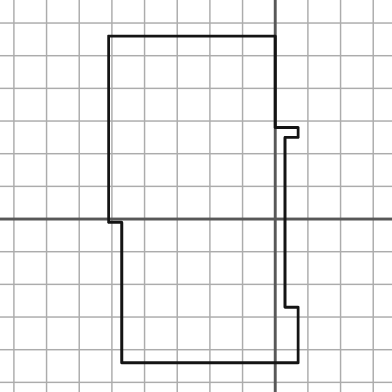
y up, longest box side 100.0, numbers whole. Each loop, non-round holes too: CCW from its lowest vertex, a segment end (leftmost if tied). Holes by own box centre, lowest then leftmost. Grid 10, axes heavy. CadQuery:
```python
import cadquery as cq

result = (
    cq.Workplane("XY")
    .moveTo(-47.0, -44.0)
    .lineTo(7.0, -44.0)
    .lineTo(7.0, -27.0)
    .lineTo(3.0, -27.0)
    .lineTo(3.0, 25.0)
    .lineTo(7.0, 25.0)
    .lineTo(7.0, 28.0)
    .lineTo(0.0, 28.0)
    .lineTo(0.0, 56.0)
    .lineTo(-51.0, 56.0)
    .lineTo(-51.0, -1.0)
    .lineTo(-47.0, -1.0)
    .close()
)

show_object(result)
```